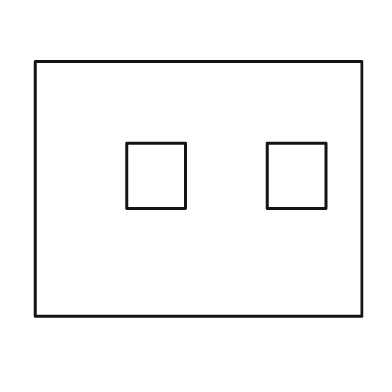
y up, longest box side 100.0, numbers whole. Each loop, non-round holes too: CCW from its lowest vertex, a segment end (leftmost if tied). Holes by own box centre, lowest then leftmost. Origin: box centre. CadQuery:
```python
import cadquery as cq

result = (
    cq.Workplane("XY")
    .moveTo(-50.0, -39.0)
    .lineTo(50.0, -39.0)
    .lineTo(50.0, 39.0)
    .lineTo(-50.0, 39.0)
    .close()
    .moveTo(-22.0, -6.0)
    .lineTo(-4.0, -6.0)
    .lineTo(-4.0, 14.0)
    .lineTo(-22.0, 14.0)
    .close()
    .moveTo(21.0, -6.0)
    .lineTo(39.0, -6.0)
    .lineTo(39.0, 14.0)
    .lineTo(21.0, 14.0)
    .close()
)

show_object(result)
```